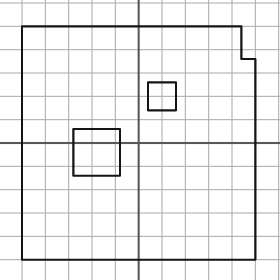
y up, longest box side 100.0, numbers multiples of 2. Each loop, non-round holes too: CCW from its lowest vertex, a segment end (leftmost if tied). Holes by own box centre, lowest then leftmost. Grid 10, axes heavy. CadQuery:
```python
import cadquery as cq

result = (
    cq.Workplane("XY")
    .moveTo(-50.0, -50.0)
    .lineTo(50.0, -50.0)
    .lineTo(50.0, 36.0)
    .lineTo(44.0, 36.0)
    .lineTo(44.0, 50.0)
    .lineTo(-50.0, 50.0)
    .close()
    .moveTo(-28.0, -14.0)
    .lineTo(-8.0, -14.0)
    .lineTo(-8.0, 6.0)
    .lineTo(-28.0, 6.0)
    .close()
    .moveTo(4.0, 14.0)
    .lineTo(16.0, 14.0)
    .lineTo(16.0, 26.0)
    .lineTo(4.0, 26.0)
    .close()
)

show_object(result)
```